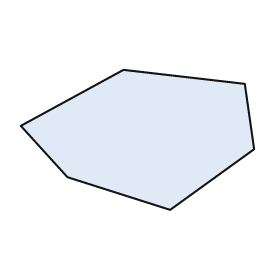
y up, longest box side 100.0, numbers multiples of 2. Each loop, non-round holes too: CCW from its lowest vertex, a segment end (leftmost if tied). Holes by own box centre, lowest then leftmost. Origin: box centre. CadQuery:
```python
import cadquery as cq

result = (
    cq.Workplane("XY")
    .moveTo(14.0, -30.0)
    .lineTo(50.0, -4.0)
    .lineTo(46.0, 24.0)
    .lineTo(-6.0, 30.0)
    .lineTo(-50.0, 6.0)
    .lineTo(-30.0, -16.0)
    .close()
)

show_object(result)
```